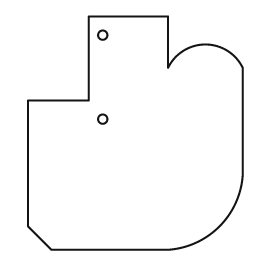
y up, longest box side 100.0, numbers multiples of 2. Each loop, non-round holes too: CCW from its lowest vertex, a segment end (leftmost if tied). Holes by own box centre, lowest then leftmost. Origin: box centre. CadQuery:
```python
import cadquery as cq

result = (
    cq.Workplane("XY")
    .moveTo(-36.0, -50.0)
    .lineTo(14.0, -50.0)
    .threePointArc((36.0, -40.0), (46.0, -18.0))
    .lineTo(46.0, 28.0)
    .threePointArc((30.0, 38.0), (14.0, 28.0))
    .lineTo(14.0, 50.0)
    .lineTo(-20.0, 50.0)
    .lineTo(-20.0, 14.0)
    .lineTo(-46.0, 14.0)
    .lineTo(-46.0, -40.0)
    .close()
    .moveTo(-14.0, 6.0)
    .circle(2.0)
    .moveTo(-14.0, 42.0)
    .circle(2.0)
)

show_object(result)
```